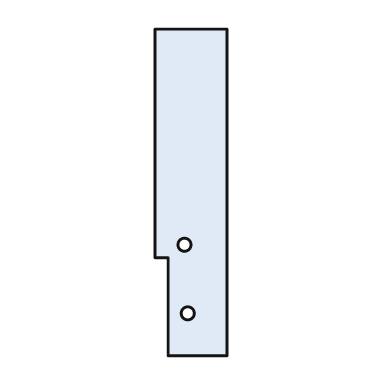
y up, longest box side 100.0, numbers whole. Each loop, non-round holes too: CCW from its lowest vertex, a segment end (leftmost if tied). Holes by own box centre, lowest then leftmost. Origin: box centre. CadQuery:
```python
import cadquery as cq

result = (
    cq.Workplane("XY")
    .moveTo(-7.0, -50.0)
    .lineTo(11.0, -50.0)
    .lineTo(11.0, 50.0)
    .lineTo(-11.0, 50.0)
    .lineTo(-11.0, -20.0)
    .lineTo(-7.0, -20.0)
    .close()
    .moveTo(-1.0, -37.0)
    .circle(2.0)
    .moveTo(-2.0, -16.0)
    .circle(2.0)
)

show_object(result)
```